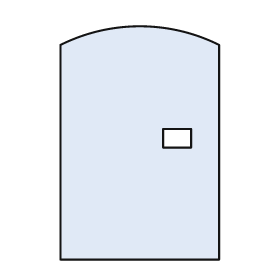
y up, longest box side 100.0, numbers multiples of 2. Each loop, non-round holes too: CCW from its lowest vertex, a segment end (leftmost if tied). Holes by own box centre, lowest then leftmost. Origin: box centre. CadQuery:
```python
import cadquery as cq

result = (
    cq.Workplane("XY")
    .moveTo(-34.0, -50.0)
    .lineTo(34.0, -50.0)
    .lineTo(34.0, 42.0)
    .threePointArc((0.0, 50.0), (-34.0, 42.0))
    .close()
    .moveTo(10.0, -2.0)
    .lineTo(22.0, -2.0)
    .lineTo(22.0, 6.0)
    .lineTo(10.0, 6.0)
    .close()
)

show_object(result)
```